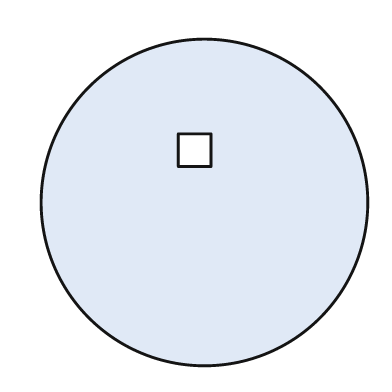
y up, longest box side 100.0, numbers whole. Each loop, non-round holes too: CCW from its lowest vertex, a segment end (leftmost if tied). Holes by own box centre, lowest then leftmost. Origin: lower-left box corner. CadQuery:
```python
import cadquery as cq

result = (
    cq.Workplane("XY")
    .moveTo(50.0, 50.0)
    .circle(50.0)
    .moveTo(42.0, 61.0)
    .lineTo(52.0, 61.0)
    .lineTo(52.0, 71.0)
    .lineTo(42.0, 71.0)
    .close()
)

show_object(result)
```